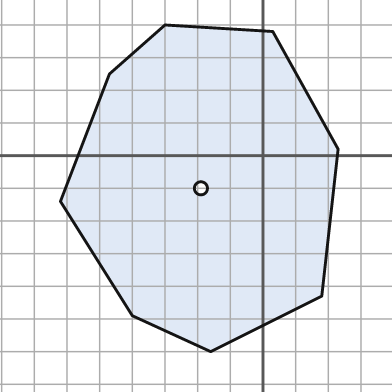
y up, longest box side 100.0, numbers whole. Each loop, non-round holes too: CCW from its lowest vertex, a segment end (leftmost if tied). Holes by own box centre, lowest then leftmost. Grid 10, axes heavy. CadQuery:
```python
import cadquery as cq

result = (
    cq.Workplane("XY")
    .moveTo(-16.0, -60.0)
    .lineTo(18.0, -43.0)
    .lineTo(23.0, 2.0)
    .lineTo(3.0, 38.0)
    .lineTo(-30.0, 40.0)
    .lineTo(-47.0, 25.0)
    .lineTo(-62.0, -14.0)
    .lineTo(-40.0, -49.0)
    .close()
    .moveTo(-19.0, -10.0)
    .circle(2.0)
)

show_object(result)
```